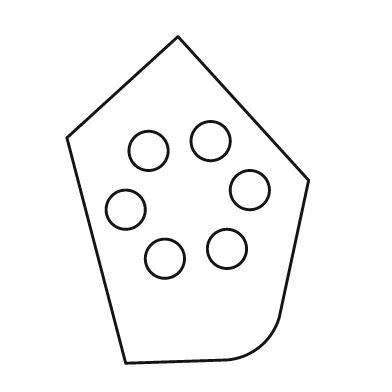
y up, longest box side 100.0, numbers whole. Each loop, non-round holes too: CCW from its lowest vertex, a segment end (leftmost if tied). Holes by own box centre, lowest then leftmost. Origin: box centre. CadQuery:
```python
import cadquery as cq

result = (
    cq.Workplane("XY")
    .moveTo(-19.0, -50.0)
    .lineTo(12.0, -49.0)
    .threePointArc((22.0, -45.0), (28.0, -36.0))
    .lineTo(37.0, 6.0)
    .lineTo(-3.0, 50.0)
    .lineTo(-37.0, 19.0)
    .close()
    .moveTo(-7.0, -18.0)
    .circle(6.0)
    .moveTo(12.0, -15.0)
    .circle(6.0)
    .moveTo(-19.0, -3.0)
    .circle(6.0)
    .moveTo(19.0, 3.0)
    .circle(6.0)
    .moveTo(-12.0, 15.0)
    .circle(6.0)
    .moveTo(7.0, 18.0)
    .circle(6.0)
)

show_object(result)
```